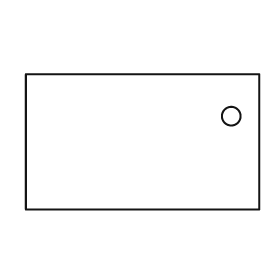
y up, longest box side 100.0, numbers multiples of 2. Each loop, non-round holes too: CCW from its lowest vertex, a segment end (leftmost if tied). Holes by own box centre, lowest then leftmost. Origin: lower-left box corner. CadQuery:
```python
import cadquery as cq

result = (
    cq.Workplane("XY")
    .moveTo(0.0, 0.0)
    .lineTo(100.0, 0.0)
    .lineTo(100.0, 58.0)
    .lineTo(0.0, 58.0)
    .close()
    .moveTo(88.0, 40.0)
    .circle(4.0)
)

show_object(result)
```